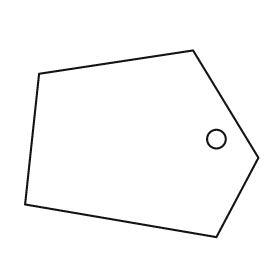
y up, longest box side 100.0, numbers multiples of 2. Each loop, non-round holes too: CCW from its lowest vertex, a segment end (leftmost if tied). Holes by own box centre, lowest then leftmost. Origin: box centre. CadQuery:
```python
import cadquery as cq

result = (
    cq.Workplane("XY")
    .moveTo(32.0, -40.0)
    .lineTo(50.0, -6.0)
    .lineTo(22.0, 40.0)
    .lineTo(-44.0, 30.0)
    .lineTo(-50.0, -26.0)
    .close()
    .moveTo(32.0, 2.0)
    .circle(4.0)
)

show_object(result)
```